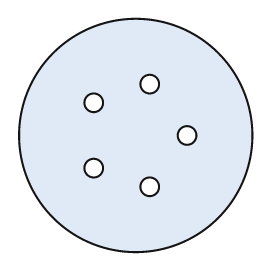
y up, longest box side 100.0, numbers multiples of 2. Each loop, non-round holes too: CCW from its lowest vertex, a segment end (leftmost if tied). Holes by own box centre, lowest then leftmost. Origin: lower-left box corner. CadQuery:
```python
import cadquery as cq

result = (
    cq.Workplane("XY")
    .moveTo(50.0, 50.0)
    .circle(50.0)
    .moveTo(56.0, 28.0)
    .circle(4.0)
    .moveTo(32.0, 36.0)
    .circle(4.0)
    .moveTo(72.0, 50.0)
    .circle(4.0)
    .moveTo(32.0, 64.0)
    .circle(4.0)
    .moveTo(56.0, 72.0)
    .circle(4.0)
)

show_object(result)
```